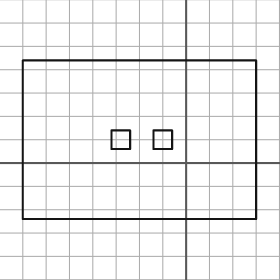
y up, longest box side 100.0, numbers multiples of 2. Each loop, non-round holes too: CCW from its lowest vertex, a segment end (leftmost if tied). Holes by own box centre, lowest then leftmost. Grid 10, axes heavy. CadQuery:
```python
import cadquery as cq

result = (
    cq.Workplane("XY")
    .moveTo(-70.0, -24.0)
    .lineTo(30.0, -24.0)
    .lineTo(30.0, 44.0)
    .lineTo(-70.0, 44.0)
    .close()
    .moveTo(-32.0, 6.0)
    .lineTo(-24.0, 6.0)
    .lineTo(-24.0, 14.0)
    .lineTo(-32.0, 14.0)
    .close()
    .moveTo(-14.0, 6.0)
    .lineTo(-6.0, 6.0)
    .lineTo(-6.0, 14.0)
    .lineTo(-14.0, 14.0)
    .close()
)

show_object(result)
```